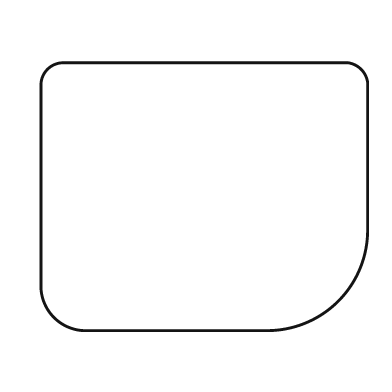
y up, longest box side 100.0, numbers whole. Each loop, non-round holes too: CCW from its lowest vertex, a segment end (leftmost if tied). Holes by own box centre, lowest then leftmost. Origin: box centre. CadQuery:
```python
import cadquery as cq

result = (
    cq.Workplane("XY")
    .moveTo(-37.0, -41.0)
    .lineTo(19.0, -41.0)
    .threePointArc((41.0, -32.0), (50.0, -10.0))
    .lineTo(50.0, 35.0)
    .threePointArc((48.0, 39.0), (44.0, 41.0))
    .lineTo(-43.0, 41.0)
    .threePointArc((-48.0, 39.0), (-50.0, 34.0))
    .lineTo(-50.0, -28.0)
    .threePointArc((-46.0, -37.0), (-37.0, -41.0))
    .close()
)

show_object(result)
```